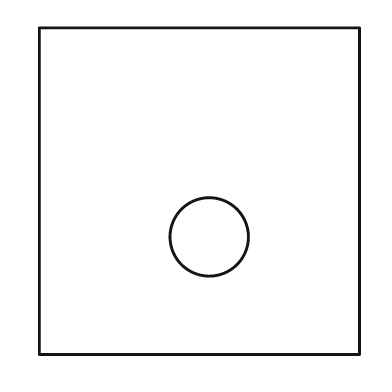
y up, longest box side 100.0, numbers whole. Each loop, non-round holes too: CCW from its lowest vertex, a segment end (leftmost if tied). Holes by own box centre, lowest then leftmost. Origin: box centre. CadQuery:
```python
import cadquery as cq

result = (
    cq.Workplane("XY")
    .moveTo(-49.0, -50.0)
    .lineTo(49.0, -50.0)
    .lineTo(49.0, 50.0)
    .lineTo(-49.0, 50.0)
    .close()
    .moveTo(3.0, -14.0)
    .circle(12.0)
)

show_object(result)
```